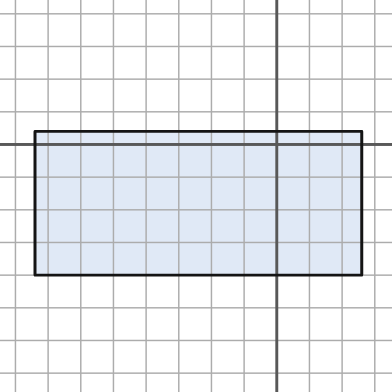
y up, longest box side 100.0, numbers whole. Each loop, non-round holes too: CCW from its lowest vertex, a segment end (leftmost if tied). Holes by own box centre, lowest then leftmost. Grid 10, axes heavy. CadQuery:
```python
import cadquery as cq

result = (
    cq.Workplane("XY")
    .moveTo(-74.0, -40.0)
    .lineTo(26.0, -40.0)
    .lineTo(26.0, 4.0)
    .lineTo(-74.0, 4.0)
    .close()
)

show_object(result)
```